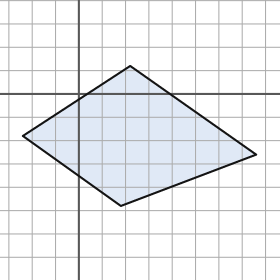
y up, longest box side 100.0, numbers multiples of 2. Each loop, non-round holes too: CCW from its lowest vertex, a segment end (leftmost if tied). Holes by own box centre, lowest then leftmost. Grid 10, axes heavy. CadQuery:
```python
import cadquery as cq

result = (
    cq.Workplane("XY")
    .moveTo(18.0, -48.0)
    .lineTo(76.0, -26.0)
    .lineTo(22.0, 12.0)
    .lineTo(-24.0, -18.0)
    .close()
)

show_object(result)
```